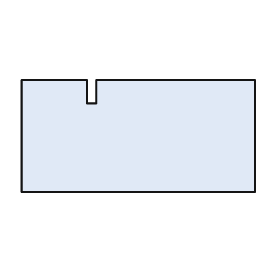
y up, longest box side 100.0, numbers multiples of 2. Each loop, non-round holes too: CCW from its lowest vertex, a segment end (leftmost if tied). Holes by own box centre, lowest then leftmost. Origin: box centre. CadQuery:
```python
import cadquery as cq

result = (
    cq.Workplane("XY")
    .moveTo(-50.0, -24.0)
    .lineTo(50.0, -24.0)
    .lineTo(50.0, 24.0)
    .lineTo(-18.0, 24.0)
    .lineTo(-18.0, 14.0)
    .lineTo(-22.0, 14.0)
    .lineTo(-22.0, 24.0)
    .lineTo(-50.0, 24.0)
    .close()
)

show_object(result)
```